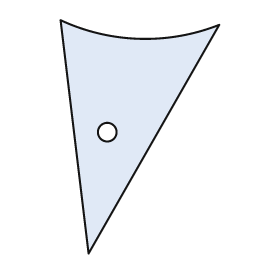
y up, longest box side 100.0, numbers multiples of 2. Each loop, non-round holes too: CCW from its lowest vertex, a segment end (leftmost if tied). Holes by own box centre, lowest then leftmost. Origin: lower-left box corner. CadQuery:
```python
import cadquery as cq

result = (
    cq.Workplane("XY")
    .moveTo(12.0, 0.0)
    .lineTo(68.0, 98.0)
    .threePointArc((34.0, 92.0), (0.0, 100.0))
    .close()
    .moveTo(20.0, 52.0)
    .circle(4.0)
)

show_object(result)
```